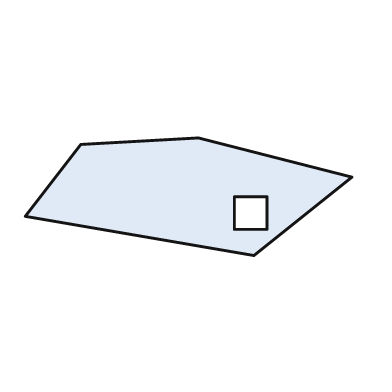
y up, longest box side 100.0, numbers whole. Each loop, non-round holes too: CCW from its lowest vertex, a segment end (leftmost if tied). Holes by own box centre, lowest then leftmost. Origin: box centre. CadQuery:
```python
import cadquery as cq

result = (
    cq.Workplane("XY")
    .moveTo(20.0, -18.0)
    .lineTo(50.0, 6.0)
    .lineTo(3.0, 18.0)
    .lineTo(-33.0, 16.0)
    .lineTo(-50.0, -6.0)
    .close()
    .moveTo(14.0, -10.0)
    .lineTo(24.0, -10.0)
    .lineTo(24.0, 0.0)
    .lineTo(14.0, 0.0)
    .close()
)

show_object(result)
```